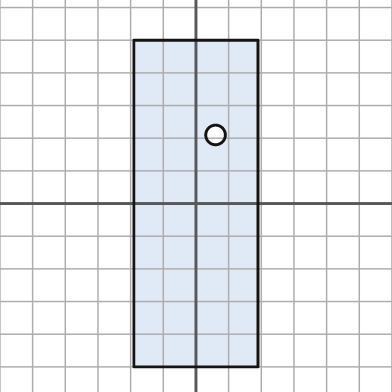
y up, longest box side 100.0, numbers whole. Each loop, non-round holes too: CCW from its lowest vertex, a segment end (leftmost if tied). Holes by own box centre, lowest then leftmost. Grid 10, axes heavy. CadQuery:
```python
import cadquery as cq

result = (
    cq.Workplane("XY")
    .moveTo(-19.0, -50.0)
    .lineTo(19.0, -50.0)
    .lineTo(19.0, 50.0)
    .lineTo(-19.0, 50.0)
    .close()
    .moveTo(6.0, 21.0)
    .circle(3.0)
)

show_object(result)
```